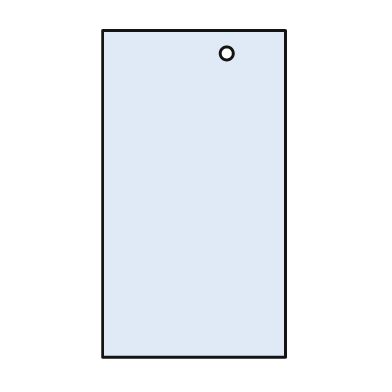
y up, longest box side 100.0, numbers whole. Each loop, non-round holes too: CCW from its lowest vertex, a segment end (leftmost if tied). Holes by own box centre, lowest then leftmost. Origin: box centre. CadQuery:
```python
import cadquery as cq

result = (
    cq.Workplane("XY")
    .moveTo(-28.0, -50.0)
    .lineTo(28.0, -50.0)
    .lineTo(28.0, 50.0)
    .lineTo(-28.0, 50.0)
    .close()
    .moveTo(10.0, 43.0)
    .circle(2.0)
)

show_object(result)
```